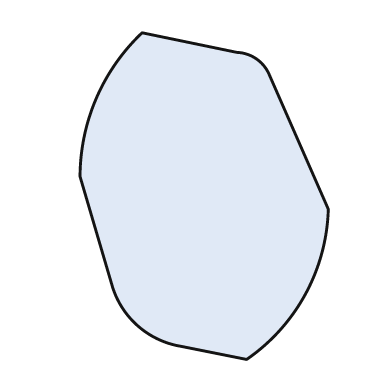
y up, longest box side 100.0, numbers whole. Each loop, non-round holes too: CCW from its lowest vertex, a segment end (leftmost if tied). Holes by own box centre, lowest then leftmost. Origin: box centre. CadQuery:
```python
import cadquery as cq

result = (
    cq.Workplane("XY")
    .moveTo(13.0, -50.0)
    .threePointArc((31.0, -30.0), (38.0, -4.0))
    .lineTo(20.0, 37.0)
    .threePointArc((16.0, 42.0), (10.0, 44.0))
    .lineTo(-19.0, 50.0)
    .threePointArc((-33.0, 30.0), (-38.0, 6.0))
    .lineTo(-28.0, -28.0)
    .threePointArc((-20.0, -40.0), (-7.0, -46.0))
    .close()
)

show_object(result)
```